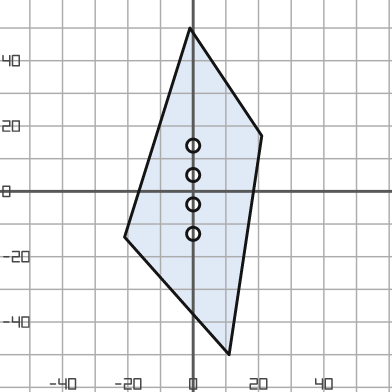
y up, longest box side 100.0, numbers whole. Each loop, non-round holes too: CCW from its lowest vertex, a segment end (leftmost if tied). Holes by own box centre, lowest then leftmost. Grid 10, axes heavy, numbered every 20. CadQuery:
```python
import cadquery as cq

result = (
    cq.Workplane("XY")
    .moveTo(11.0, -50.0)
    .lineTo(21.0, 17.0)
    .lineTo(-1.0, 50.0)
    .lineTo(-21.0, -14.0)
    .close()
    .moveTo(0.0, -13.0)
    .circle(2.0)
    .moveTo(0.0, -4.0)
    .circle(2.0)
    .moveTo(0.0, 5.0)
    .circle(2.0)
    .moveTo(0.0, 14.0)
    .circle(2.0)
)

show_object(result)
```